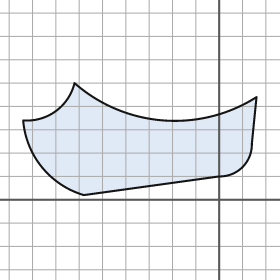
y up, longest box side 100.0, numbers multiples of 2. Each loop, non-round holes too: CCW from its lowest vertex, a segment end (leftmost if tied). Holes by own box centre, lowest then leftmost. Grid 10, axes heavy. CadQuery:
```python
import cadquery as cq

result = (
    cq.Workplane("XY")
    .moveTo(-58.0, 2.0)
    .lineTo(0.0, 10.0)
    .threePointArc((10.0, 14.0), (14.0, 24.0))
    .lineTo(16.0, 44.0)
    .threePointArc((-24.0, 34.0), (-62.0, 50.0))
    .threePointArc((-70.0, 38.0), (-84.0, 34.0))
    .threePointArc((-76.0, 14.0), (-58.0, 2.0))
    .close()
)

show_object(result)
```